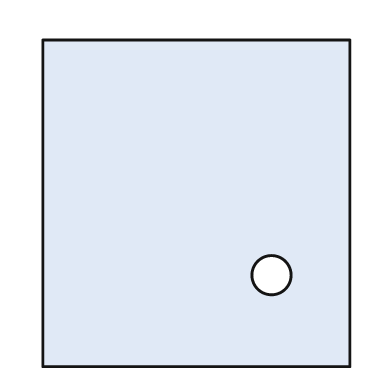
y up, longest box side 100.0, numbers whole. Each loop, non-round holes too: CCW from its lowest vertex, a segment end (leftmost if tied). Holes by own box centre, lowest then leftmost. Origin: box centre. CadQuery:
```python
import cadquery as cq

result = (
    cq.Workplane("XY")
    .moveTo(-47.0, -50.0)
    .lineTo(47.0, -50.0)
    .lineTo(47.0, 50.0)
    .lineTo(-47.0, 50.0)
    .close()
    .moveTo(23.0, -22.0)
    .circle(6.0)
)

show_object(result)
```